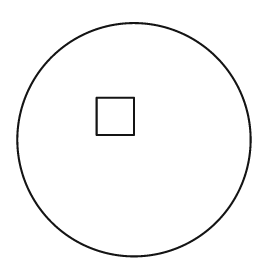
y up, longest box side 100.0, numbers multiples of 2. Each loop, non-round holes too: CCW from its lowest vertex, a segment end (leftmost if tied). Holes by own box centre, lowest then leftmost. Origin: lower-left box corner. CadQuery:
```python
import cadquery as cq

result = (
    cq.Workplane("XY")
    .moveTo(50.0, 50.0)
    .circle(50.0)
    .moveTo(34.0, 52.0)
    .lineTo(50.0, 52.0)
    .lineTo(50.0, 68.0)
    .lineTo(34.0, 68.0)
    .close()
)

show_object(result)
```